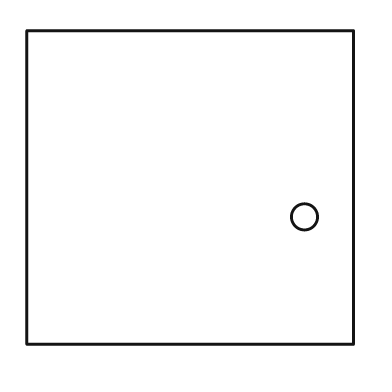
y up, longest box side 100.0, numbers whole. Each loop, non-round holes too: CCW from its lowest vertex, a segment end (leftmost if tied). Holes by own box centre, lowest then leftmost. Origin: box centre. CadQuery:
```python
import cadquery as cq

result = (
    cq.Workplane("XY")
    .moveTo(-50.0, -48.0)
    .lineTo(50.0, -48.0)
    .lineTo(50.0, 48.0)
    .lineTo(-50.0, 48.0)
    .close()
    .moveTo(35.0, -9.0)
    .circle(4.0)
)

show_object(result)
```